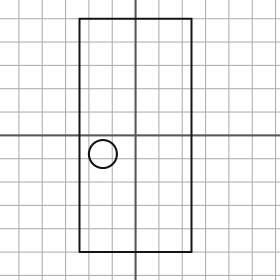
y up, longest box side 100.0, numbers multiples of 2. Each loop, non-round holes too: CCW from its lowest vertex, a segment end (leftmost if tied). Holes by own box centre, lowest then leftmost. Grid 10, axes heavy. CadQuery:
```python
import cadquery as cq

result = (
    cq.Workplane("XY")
    .moveTo(-24.0, -50.0)
    .lineTo(24.0, -50.0)
    .lineTo(24.0, 50.0)
    .lineTo(-24.0, 50.0)
    .close()
    .moveTo(-14.0, -8.0)
    .circle(6.0)
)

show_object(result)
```